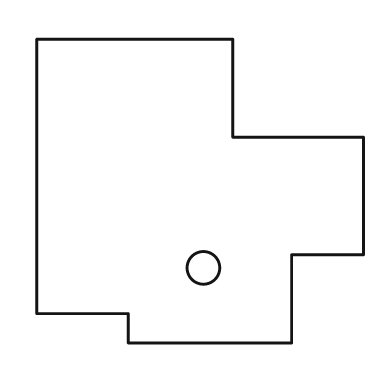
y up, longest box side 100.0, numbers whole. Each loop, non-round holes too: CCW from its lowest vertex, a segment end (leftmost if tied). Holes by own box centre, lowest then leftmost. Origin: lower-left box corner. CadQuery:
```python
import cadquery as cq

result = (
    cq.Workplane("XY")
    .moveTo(28.0, 0.0)
    .lineTo(78.0, 0.0)
    .lineTo(78.0, 27.0)
    .lineTo(100.0, 27.0)
    .lineTo(100.0, 63.0)
    .lineTo(60.0, 63.0)
    .lineTo(60.0, 93.0)
    .lineTo(0.0, 93.0)
    .lineTo(0.0, 9.0)
    .lineTo(28.0, 9.0)
    .close()
    .moveTo(51.0, 23.0)
    .circle(5.0)
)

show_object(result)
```